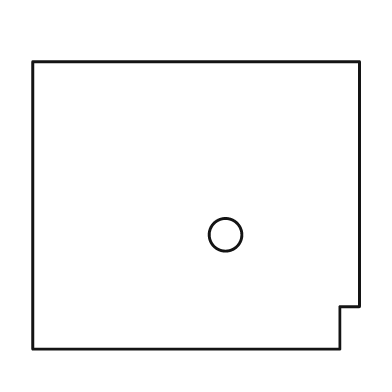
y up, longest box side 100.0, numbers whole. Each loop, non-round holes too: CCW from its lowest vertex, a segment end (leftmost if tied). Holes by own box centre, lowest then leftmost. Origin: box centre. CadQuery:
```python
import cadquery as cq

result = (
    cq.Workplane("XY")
    .moveTo(-50.0, -44.0)
    .lineTo(44.0, -44.0)
    .lineTo(44.0, -31.0)
    .lineTo(50.0, -31.0)
    .lineTo(50.0, 44.0)
    .lineTo(-50.0, 44.0)
    .close()
    .moveTo(9.0, -9.0)
    .circle(5.0)
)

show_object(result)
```